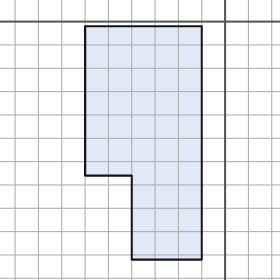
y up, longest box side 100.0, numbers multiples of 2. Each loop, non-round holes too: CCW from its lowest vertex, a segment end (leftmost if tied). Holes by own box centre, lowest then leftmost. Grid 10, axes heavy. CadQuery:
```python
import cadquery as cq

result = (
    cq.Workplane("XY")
    .moveTo(-40.0, -102.0)
    .lineTo(-10.0, -102.0)
    .lineTo(-10.0, -2.0)
    .lineTo(-60.0, -2.0)
    .lineTo(-60.0, -66.0)
    .lineTo(-40.0, -66.0)
    .close()
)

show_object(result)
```